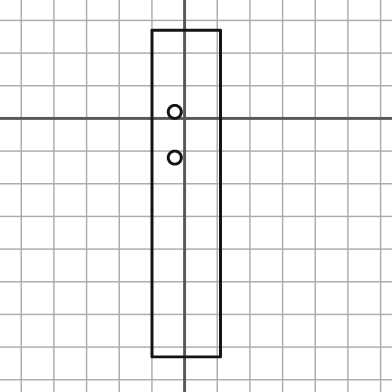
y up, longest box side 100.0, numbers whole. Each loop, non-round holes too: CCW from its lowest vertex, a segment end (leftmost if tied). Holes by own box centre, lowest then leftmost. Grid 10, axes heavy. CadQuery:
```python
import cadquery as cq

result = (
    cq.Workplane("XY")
    .moveTo(-10.0, -73.0)
    .lineTo(11.0, -73.0)
    .lineTo(11.0, 27.0)
    .lineTo(-10.0, 27.0)
    .close()
    .moveTo(-3.0, -12.0)
    .circle(2.0)
    .moveTo(-3.0, 2.0)
    .circle(2.0)
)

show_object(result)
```